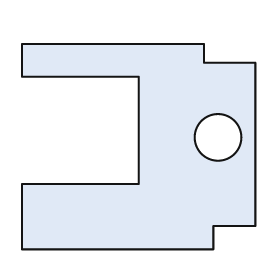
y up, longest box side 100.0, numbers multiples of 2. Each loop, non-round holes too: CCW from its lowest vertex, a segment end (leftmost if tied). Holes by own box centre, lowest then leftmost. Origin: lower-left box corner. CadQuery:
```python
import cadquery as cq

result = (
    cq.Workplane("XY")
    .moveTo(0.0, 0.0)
    .lineTo(82.0, 0.0)
    .lineTo(82.0, 10.0)
    .lineTo(100.0, 10.0)
    .lineTo(100.0, 80.0)
    .lineTo(78.0, 80.0)
    .lineTo(78.0, 88.0)
    .lineTo(0.0, 88.0)
    .lineTo(0.0, 74.0)
    .lineTo(50.0, 74.0)
    .lineTo(50.0, 28.0)
    .lineTo(0.0, 28.0)
    .close()
    .moveTo(84.0, 48.0)
    .circle(10.0)
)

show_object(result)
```